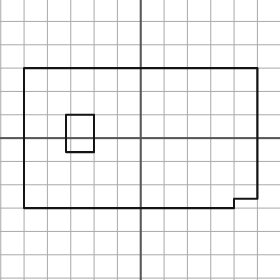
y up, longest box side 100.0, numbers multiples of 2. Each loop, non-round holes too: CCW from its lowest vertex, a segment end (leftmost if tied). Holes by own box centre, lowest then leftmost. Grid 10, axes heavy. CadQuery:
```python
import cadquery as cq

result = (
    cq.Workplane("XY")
    .moveTo(-50.0, -30.0)
    .lineTo(40.0, -30.0)
    .lineTo(40.0, -26.0)
    .lineTo(50.0, -26.0)
    .lineTo(50.0, 30.0)
    .lineTo(-50.0, 30.0)
    .close()
    .moveTo(-32.0, -6.0)
    .lineTo(-20.0, -6.0)
    .lineTo(-20.0, 10.0)
    .lineTo(-32.0, 10.0)
    .close()
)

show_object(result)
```